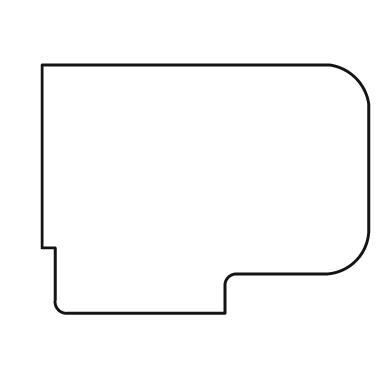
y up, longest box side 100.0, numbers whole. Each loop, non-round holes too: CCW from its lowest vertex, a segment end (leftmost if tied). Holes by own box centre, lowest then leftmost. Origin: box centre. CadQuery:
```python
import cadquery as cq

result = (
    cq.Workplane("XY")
    .moveTo(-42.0, -38.0)
    .lineTo(6.0, -38.0)
    .lineTo(6.0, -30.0)
    .threePointArc((7.0, -27.0), (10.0, -26.0))
    .lineTo(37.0, -26.0)
    .threePointArc((46.0, -22.0), (50.0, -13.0))
    .lineTo(50.0, 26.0)
    .threePointArc((46.0, 34.0), (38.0, 38.0))
    .lineTo(-50.0, 38.0)
    .lineTo(-50.0, -18.0)
    .lineTo(-46.0, -18.0)
    .lineTo(-46.0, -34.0)
    .threePointArc((-45.0, -37.0), (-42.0, -38.0))
    .close()
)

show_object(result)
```